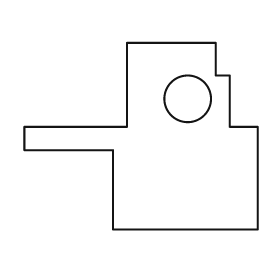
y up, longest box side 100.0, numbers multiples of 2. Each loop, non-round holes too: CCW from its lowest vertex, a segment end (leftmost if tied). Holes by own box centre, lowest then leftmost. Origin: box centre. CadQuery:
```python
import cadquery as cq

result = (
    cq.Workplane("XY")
    .moveTo(-12.0, -40.0)
    .lineTo(50.0, -40.0)
    .lineTo(50.0, 4.0)
    .lineTo(38.0, 4.0)
    .lineTo(38.0, 26.0)
    .lineTo(32.0, 26.0)
    .lineTo(32.0, 40.0)
    .lineTo(-6.0, 40.0)
    .lineTo(-6.0, 4.0)
    .lineTo(-50.0, 4.0)
    .lineTo(-50.0, -6.0)
    .lineTo(-12.0, -6.0)
    .close()
    .moveTo(20.0, 16.0)
    .circle(10.0)
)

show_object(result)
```